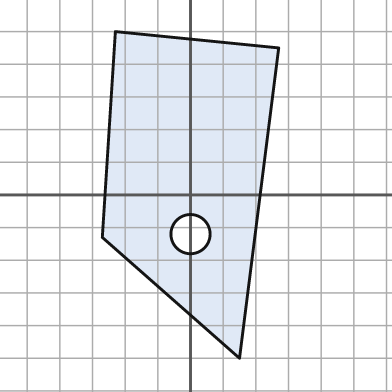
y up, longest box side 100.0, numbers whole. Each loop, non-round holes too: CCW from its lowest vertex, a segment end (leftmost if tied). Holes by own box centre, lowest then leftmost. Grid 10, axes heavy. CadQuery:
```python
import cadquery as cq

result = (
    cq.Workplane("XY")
    .moveTo(15.0, -50.0)
    .lineTo(27.0, 45.0)
    .lineTo(-23.0, 50.0)
    .lineTo(-27.0, -13.0)
    .close()
    .moveTo(0.0, -12.0)
    .circle(6.0)
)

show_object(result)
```